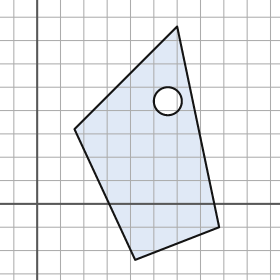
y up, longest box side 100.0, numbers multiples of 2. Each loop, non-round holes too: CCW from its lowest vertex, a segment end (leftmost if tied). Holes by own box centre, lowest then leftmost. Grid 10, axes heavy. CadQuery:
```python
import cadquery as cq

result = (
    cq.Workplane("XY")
    .moveTo(42.0, -24.0)
    .lineTo(78.0, -10.0)
    .lineTo(60.0, 76.0)
    .lineTo(16.0, 32.0)
    .close()
    .moveTo(56.0, 44.0)
    .circle(6.0)
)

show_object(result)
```